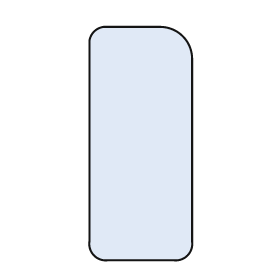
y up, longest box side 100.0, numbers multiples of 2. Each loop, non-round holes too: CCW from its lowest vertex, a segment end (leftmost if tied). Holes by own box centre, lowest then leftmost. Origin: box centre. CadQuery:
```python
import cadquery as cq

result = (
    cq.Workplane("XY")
    .moveTo(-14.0, -50.0)
    .lineTo(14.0, -50.0)
    .threePointArc((20.0, -48.0), (22.0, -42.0))
    .lineTo(22.0, 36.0)
    .threePointArc((18.0, 46.0), (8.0, 50.0))
    .lineTo(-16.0, 50.0)
    .threePointArc((-20.0, 48.0), (-22.0, 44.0))
    .lineTo(-22.0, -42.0)
    .threePointArc((-20.0, -48.0), (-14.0, -50.0))
    .close()
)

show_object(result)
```